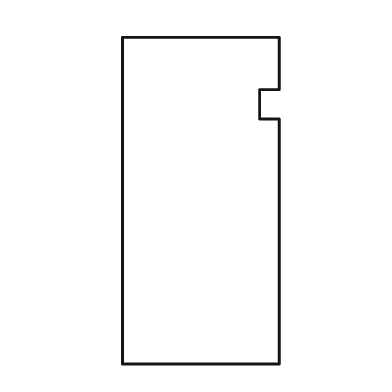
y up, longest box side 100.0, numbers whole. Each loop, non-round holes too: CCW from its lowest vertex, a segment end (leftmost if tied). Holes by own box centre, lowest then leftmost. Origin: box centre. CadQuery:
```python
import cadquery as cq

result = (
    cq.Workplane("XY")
    .moveTo(-24.0, -50.0)
    .lineTo(24.0, -50.0)
    .lineTo(24.0, 25.0)
    .lineTo(18.0, 25.0)
    .lineTo(18.0, 34.0)
    .lineTo(24.0, 34.0)
    .lineTo(24.0, 50.0)
    .lineTo(-24.0, 50.0)
    .close()
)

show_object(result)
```